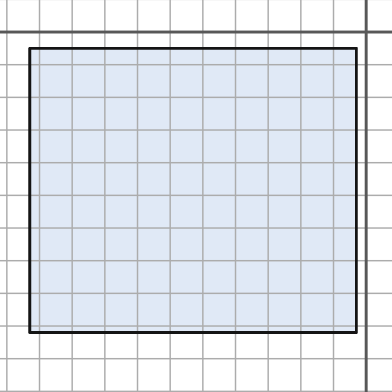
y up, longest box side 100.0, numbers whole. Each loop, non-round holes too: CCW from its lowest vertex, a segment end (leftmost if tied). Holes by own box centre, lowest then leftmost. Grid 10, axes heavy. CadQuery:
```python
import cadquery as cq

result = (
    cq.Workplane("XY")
    .moveTo(-103.0, -92.0)
    .lineTo(-3.0, -92.0)
    .lineTo(-3.0, -5.0)
    .lineTo(-103.0, -5.0)
    .close()
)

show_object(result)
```